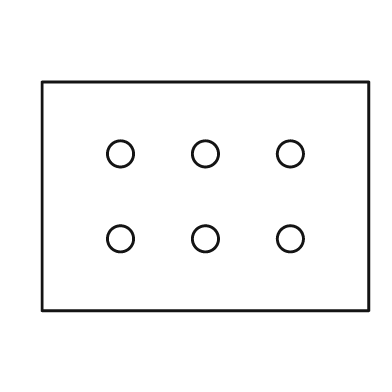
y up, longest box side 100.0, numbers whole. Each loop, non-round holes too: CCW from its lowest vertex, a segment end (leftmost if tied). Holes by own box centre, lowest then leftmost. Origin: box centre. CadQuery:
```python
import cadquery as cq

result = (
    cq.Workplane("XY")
    .moveTo(-50.0, -35.0)
    .lineTo(50.0, -35.0)
    .lineTo(50.0, 35.0)
    .lineTo(-50.0, 35.0)
    .close()
    .moveTo(-26.0, -13.0)
    .circle(4.0)
    .moveTo(0.0, -13.0)
    .circle(4.0)
    .moveTo(26.0, -13.0)
    .circle(4.0)
    .moveTo(-26.0, 13.0)
    .circle(4.0)
    .moveTo(0.0, 13.0)
    .circle(4.0)
    .moveTo(26.0, 13.0)
    .circle(4.0)
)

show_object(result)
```